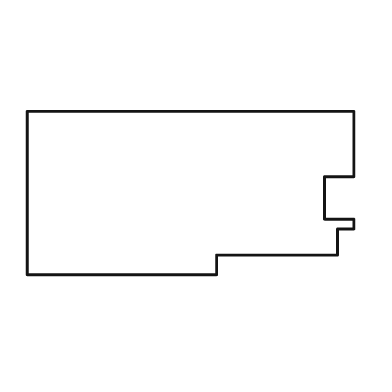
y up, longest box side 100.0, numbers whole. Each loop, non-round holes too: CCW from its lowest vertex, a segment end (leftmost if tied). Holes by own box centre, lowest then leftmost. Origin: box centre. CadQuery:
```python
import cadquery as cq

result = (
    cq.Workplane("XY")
    .moveTo(-50.0, -25.0)
    .lineTo(8.0, -25.0)
    .lineTo(8.0, -19.0)
    .lineTo(45.0, -19.0)
    .lineTo(45.0, -11.0)
    .lineTo(50.0, -11.0)
    .lineTo(50.0, -8.0)
    .lineTo(41.0, -8.0)
    .lineTo(41.0, 5.0)
    .lineTo(50.0, 5.0)
    .lineTo(50.0, 25.0)
    .lineTo(-50.0, 25.0)
    .close()
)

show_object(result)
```